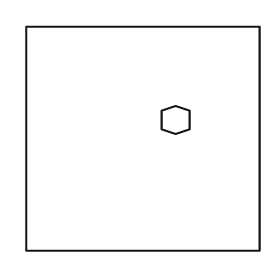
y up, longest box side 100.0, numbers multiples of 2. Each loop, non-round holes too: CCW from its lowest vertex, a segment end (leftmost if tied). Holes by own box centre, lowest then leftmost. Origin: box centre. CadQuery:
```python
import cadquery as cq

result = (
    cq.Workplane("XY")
    .moveTo(-50.0, -48.0)
    .lineTo(50.0, -48.0)
    .lineTo(50.0, 48.0)
    .lineTo(-50.0, 48.0)
    .close()
    .moveTo(14.0, 2.0)
    .lineTo(20.0, 4.0)
    .lineTo(20.0, 12.0)
    .lineTo(14.0, 14.0)
    .lineTo(8.0, 12.0)
    .lineTo(8.0, 4.0)
    .close()
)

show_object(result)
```